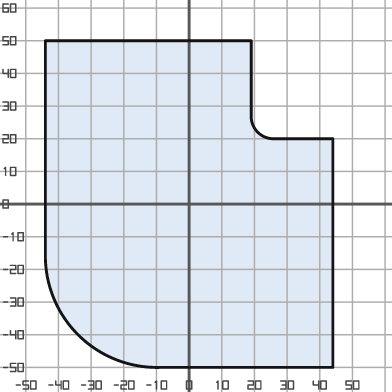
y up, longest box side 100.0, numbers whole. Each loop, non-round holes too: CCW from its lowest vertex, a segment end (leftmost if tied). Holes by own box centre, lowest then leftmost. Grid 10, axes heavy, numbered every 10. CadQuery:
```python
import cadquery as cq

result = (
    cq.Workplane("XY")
    .moveTo(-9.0, -50.0)
    .lineTo(44.0, -50.0)
    .lineTo(44.0, 20.0)
    .lineTo(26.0, 20.0)
    .threePointArc((21.0, 22.0), (19.0, 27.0))
    .lineTo(19.0, 50.0)
    .lineTo(-44.0, 50.0)
    .lineTo(-44.0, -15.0)
    .threePointArc((-34.0, -40.0), (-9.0, -50.0))
    .close()
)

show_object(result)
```